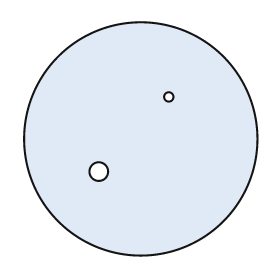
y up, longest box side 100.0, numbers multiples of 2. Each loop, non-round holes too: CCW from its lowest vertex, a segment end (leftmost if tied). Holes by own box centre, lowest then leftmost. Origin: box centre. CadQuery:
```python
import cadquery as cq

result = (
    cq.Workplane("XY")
    .moveTo(0.0, 0.0)
    .circle(50.0)
    .moveTo(-18.0, -14.0)
    .circle(4.0)
    .moveTo(12.0, 18.0)
    .circle(2.0)
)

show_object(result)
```